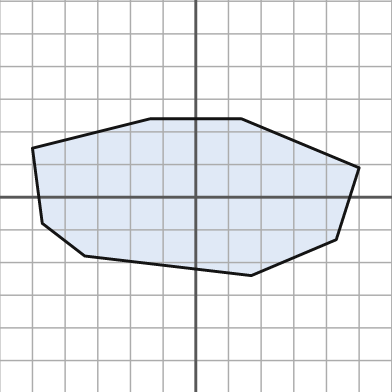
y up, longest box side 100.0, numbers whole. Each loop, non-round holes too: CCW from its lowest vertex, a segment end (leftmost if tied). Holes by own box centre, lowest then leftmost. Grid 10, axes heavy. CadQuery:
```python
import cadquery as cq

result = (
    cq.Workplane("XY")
    .moveTo(17.0, -24.0)
    .lineTo(43.0, -13.0)
    .lineTo(50.0, 9.0)
    .lineTo(14.0, 24.0)
    .lineTo(-14.0, 24.0)
    .lineTo(-50.0, 15.0)
    .lineTo(-47.0, -8.0)
    .lineTo(-34.0, -18.0)
    .close()
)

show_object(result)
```